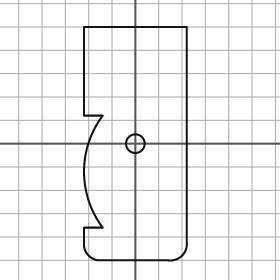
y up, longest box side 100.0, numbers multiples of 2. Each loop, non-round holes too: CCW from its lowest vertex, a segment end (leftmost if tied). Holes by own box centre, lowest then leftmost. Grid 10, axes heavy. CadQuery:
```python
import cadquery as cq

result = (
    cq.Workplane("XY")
    .moveTo(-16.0, -50.0)
    .lineTo(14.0, -50.0)
    .threePointArc((20.0, -48.0), (22.0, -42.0))
    .lineTo(22.0, 50.0)
    .lineTo(-22.0, 50.0)
    .lineTo(-22.0, 12.0)
    .lineTo(-14.0, 12.0)
    .threePointArc((-22.0, -12.0), (-14.0, -36.0))
    .lineTo(-22.0, -36.0)
    .lineTo(-22.0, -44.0)
    .threePointArc((-20.0, -48.0), (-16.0, -50.0))
    .close()
    .moveTo(0.0, 0.0)
    .circle(4.0)
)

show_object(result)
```